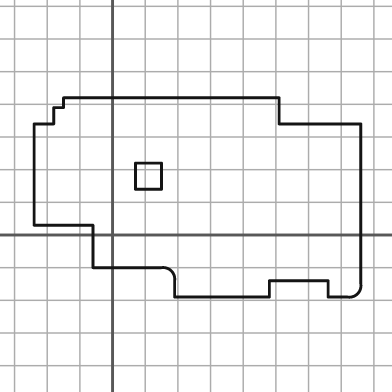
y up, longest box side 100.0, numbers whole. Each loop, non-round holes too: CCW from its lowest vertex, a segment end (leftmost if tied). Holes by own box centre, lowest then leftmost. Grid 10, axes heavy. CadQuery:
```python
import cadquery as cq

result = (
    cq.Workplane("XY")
    .moveTo(19.0, -19.0)
    .lineTo(48.0, -19.0)
    .lineTo(48.0, -14.0)
    .lineTo(66.0, -14.0)
    .lineTo(66.0, -19.0)
    .lineTo(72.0, -19.0)
    .threePointArc((75.0, -18.0), (76.0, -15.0))
    .lineTo(76.0, 34.0)
    .lineTo(51.0, 34.0)
    .lineTo(51.0, 42.0)
    .lineTo(-15.0, 42.0)
    .lineTo(-15.0, 39.0)
    .lineTo(-18.0, 39.0)
    .lineTo(-18.0, 34.0)
    .lineTo(-24.0, 34.0)
    .lineTo(-24.0, 3.0)
    .lineTo(-6.0, 3.0)
    .lineTo(-6.0, -10.0)
    .lineTo(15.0, -10.0)
    .threePointArc((18.0, -11.0), (19.0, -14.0))
    .close()
    .moveTo(7.0, 14.0)
    .lineTo(15.0, 14.0)
    .lineTo(15.0, 22.0)
    .lineTo(7.0, 22.0)
    .close()
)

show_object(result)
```